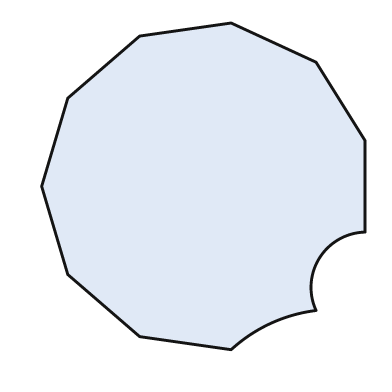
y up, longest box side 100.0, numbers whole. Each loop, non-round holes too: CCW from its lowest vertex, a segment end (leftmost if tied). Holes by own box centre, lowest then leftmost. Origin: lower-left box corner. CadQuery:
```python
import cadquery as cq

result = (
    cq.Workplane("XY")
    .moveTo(58.0, 0.0)
    .threePointArc((70.0, 8.0), (84.0, 12.0))
    .threePointArc((85.0, 28.0), (99.0, 36.0))
    .lineTo(99.0, 64.0)
    .lineTo(84.0, 88.0)
    .lineTo(58.0, 100.0)
    .lineTo(30.0, 96.0)
    .lineTo(8.0, 77.0)
    .lineTo(0.0, 50.0)
    .lineTo(8.0, 23.0)
    .lineTo(30.0, 4.0)
    .close()
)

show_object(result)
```